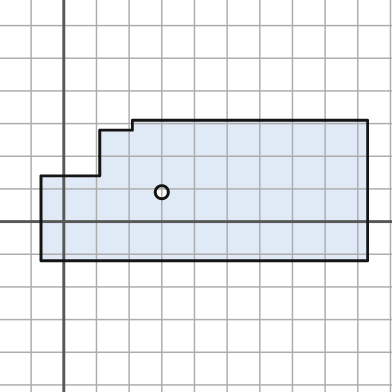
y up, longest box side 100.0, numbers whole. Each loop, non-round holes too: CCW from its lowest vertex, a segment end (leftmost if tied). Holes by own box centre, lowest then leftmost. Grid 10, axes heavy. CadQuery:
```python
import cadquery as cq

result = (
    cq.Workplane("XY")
    .moveTo(-7.0, -12.0)
    .lineTo(93.0, -12.0)
    .lineTo(93.0, 31.0)
    .lineTo(21.0, 31.0)
    .lineTo(21.0, 28.0)
    .lineTo(11.0, 28.0)
    .lineTo(11.0, 14.0)
    .lineTo(-7.0, 14.0)
    .close()
    .moveTo(30.0, 9.0)
    .circle(2.0)
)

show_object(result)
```